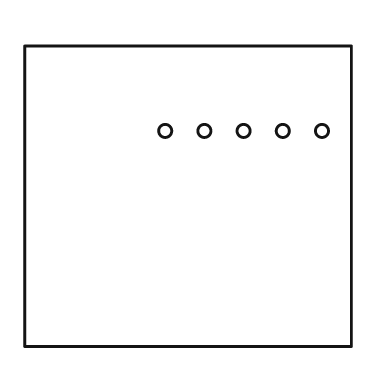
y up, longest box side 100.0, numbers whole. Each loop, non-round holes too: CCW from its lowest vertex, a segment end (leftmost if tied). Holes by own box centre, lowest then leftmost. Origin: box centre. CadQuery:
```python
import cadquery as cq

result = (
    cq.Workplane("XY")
    .moveTo(-50.0, -46.0)
    .lineTo(50.0, -46.0)
    .lineTo(50.0, 46.0)
    .lineTo(-50.0, 46.0)
    .close()
    .moveTo(-7.0, 20.0)
    .circle(2.0)
    .moveTo(5.0, 20.0)
    .circle(2.0)
    .moveTo(17.0, 20.0)
    .circle(2.0)
    .moveTo(29.0, 20.0)
    .circle(2.0)
    .moveTo(41.0, 20.0)
    .circle(2.0)
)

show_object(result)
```